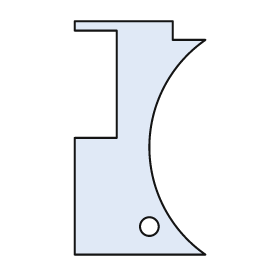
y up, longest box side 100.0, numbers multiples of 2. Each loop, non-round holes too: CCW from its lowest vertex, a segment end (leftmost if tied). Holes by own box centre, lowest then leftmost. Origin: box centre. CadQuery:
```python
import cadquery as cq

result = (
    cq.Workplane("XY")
    .moveTo(-28.0, -50.0)
    .lineTo(28.0, -50.0)
    .threePointArc((4.0, -4.0), (28.0, 42.0))
    .lineTo(14.0, 42.0)
    .lineTo(14.0, 50.0)
    .lineTo(-28.0, 50.0)
    .lineTo(-28.0, 46.0)
    .lineTo(-10.0, 46.0)
    .lineTo(-10.0, 0.0)
    .lineTo(-28.0, 0.0)
    .close()
    .moveTo(4.0, -38.0)
    .circle(4.0)
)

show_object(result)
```